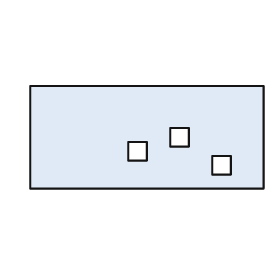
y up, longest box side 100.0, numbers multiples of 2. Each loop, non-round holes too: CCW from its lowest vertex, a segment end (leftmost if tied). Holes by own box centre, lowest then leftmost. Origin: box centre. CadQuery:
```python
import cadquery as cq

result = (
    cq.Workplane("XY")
    .moveTo(-50.0, -22.0)
    .lineTo(50.0, -22.0)
    .lineTo(50.0, 22.0)
    .lineTo(-50.0, 22.0)
    .close()
    .moveTo(28.0, -16.0)
    .lineTo(36.0, -16.0)
    .lineTo(36.0, -8.0)
    .lineTo(28.0, -8.0)
    .close()
    .moveTo(-8.0, -10.0)
    .lineTo(0.0, -10.0)
    .lineTo(0.0, -2.0)
    .lineTo(-8.0, -2.0)
    .close()
    .moveTo(10.0, -4.0)
    .lineTo(18.0, -4.0)
    .lineTo(18.0, 4.0)
    .lineTo(10.0, 4.0)
    .close()
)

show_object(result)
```